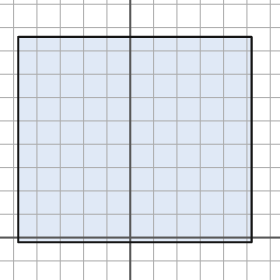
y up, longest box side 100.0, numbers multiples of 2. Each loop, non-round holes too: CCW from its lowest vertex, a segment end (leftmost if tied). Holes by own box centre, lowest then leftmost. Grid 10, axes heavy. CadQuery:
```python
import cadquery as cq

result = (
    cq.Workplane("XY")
    .moveTo(-48.0, -2.0)
    .lineTo(52.0, -2.0)
    .lineTo(52.0, 86.0)
    .lineTo(-48.0, 86.0)
    .close()
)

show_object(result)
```